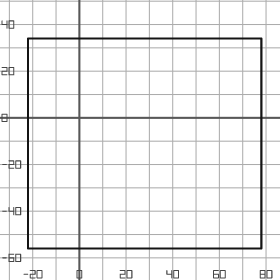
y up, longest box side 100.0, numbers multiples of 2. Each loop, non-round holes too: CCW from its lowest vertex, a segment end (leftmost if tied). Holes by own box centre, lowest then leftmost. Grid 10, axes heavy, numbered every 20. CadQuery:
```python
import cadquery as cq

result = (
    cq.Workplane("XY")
    .moveTo(-22.0, -56.0)
    .lineTo(78.0, -56.0)
    .lineTo(78.0, 34.0)
    .lineTo(-22.0, 34.0)
    .close()
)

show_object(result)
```